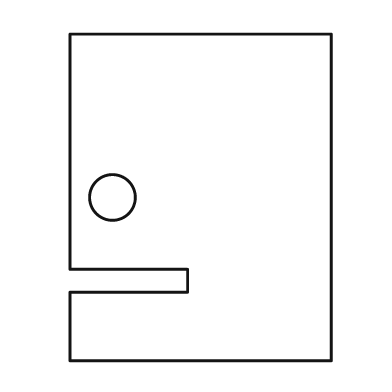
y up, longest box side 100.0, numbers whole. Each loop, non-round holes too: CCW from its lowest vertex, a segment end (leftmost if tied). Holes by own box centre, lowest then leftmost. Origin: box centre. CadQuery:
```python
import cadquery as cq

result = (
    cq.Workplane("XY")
    .moveTo(-40.0, -50.0)
    .lineTo(40.0, -50.0)
    .lineTo(40.0, 50.0)
    .lineTo(-40.0, 50.0)
    .lineTo(-40.0, -22.0)
    .lineTo(-4.0, -22.0)
    .lineTo(-4.0, -29.0)
    .lineTo(-40.0, -29.0)
    .close()
    .moveTo(-27.0, 0.0)
    .circle(7.0)
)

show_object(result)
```